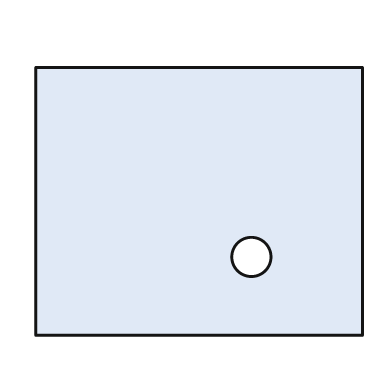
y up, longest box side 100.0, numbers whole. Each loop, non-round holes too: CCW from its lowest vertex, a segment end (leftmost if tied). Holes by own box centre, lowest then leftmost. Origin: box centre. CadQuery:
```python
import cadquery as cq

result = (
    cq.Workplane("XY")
    .moveTo(-50.0, -41.0)
    .lineTo(50.0, -41.0)
    .lineTo(50.0, 41.0)
    .lineTo(-50.0, 41.0)
    .close()
    .moveTo(16.0, -17.0)
    .circle(6.0)
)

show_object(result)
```